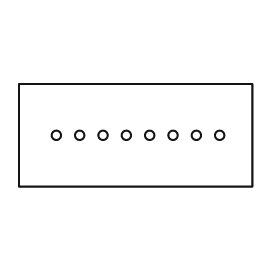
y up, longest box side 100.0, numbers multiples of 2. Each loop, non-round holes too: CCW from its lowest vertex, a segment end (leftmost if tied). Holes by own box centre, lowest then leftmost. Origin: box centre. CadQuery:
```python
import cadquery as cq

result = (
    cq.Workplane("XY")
    .moveTo(-50.0, -22.0)
    .lineTo(50.0, -22.0)
    .lineTo(50.0, 22.0)
    .lineTo(-50.0, 22.0)
    .close()
    .moveTo(-34.0, 0.0)
    .circle(2.0)
    .moveTo(-24.0, 0.0)
    .circle(2.0)
    .moveTo(-14.0, 0.0)
    .circle(2.0)
    .moveTo(-4.0, 0.0)
    .circle(2.0)
    .moveTo(6.0, 0.0)
    .circle(2.0)
    .moveTo(16.0, 0.0)
    .circle(2.0)
    .moveTo(26.0, 0.0)
    .circle(2.0)
    .moveTo(36.0, 0.0)
    .circle(2.0)
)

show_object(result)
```